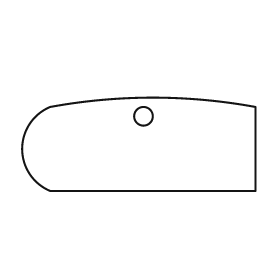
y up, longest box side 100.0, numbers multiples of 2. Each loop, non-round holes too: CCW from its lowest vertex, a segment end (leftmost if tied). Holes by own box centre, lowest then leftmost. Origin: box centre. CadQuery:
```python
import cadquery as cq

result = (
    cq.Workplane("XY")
    .moveTo(-38.0, -20.0)
    .lineTo(50.0, -20.0)
    .lineTo(50.0, 16.0)
    .threePointArc((6.0, 20.0), (-38.0, 16.0))
    .threePointArc((-50.0, -2.0), (-38.0, -20.0))
    .close()
    .moveTo(2.0, 12.0)
    .circle(4.0)
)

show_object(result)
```